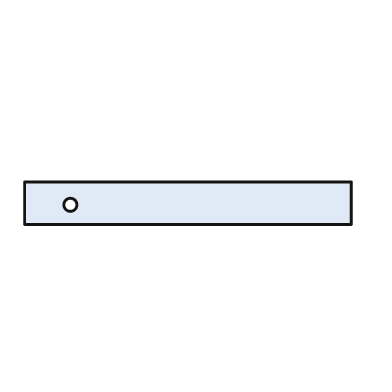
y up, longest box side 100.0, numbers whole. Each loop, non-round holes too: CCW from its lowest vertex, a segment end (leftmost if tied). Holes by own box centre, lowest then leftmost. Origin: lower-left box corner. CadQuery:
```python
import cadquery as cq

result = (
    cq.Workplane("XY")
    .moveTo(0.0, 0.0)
    .lineTo(100.0, 0.0)
    .lineTo(100.0, 13.0)
    .lineTo(0.0, 13.0)
    .close()
    .moveTo(14.0, 6.0)
    .circle(2.0)
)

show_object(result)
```